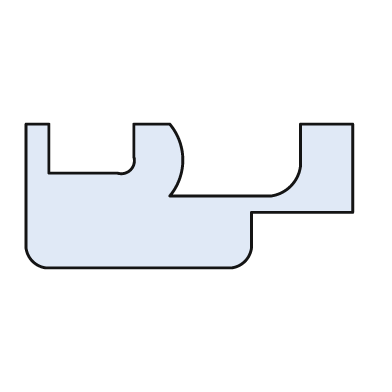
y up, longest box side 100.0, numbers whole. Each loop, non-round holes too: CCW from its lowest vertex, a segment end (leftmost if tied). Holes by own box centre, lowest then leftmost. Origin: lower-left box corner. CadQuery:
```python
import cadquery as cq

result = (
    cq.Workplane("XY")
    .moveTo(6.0, 0.0)
    .lineTo(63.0, 0.0)
    .threePointArc((67.0, 2.0), (69.0, 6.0))
    .lineTo(69.0, 17.0)
    .lineTo(100.0, 17.0)
    .lineTo(100.0, 44.0)
    .lineTo(84.0, 44.0)
    .lineTo(84.0, 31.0)
    .threePointArc((81.0, 25.0), (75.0, 22.0))
    .lineTo(44.0, 22.0)
    .threePointArc((48.0, 33.0), (44.0, 44.0))
    .lineTo(33.0, 44.0)
    .lineTo(33.0, 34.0)
    .threePointArc((32.0, 30.0), (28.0, 29.0))
    .lineTo(7.0, 29.0)
    .lineTo(7.0, 44.0)
    .lineTo(0.0, 44.0)
    .lineTo(0.0, 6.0)
    .threePointArc((2.0, 2.0), (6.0, 0.0))
    .close()
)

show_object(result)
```